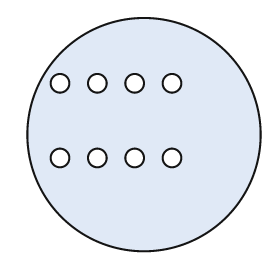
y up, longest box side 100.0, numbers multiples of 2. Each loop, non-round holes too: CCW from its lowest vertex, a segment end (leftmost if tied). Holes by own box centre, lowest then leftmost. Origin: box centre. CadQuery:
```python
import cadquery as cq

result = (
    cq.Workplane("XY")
    .moveTo(0.0, 0.0)
    .circle(50.0)
    .moveTo(-36.0, -10.0)
    .circle(4.0)
    .moveTo(-20.0, -10.0)
    .circle(4.0)
    .moveTo(-4.0, -10.0)
    .circle(4.0)
    .moveTo(12.0, -10.0)
    .circle(4.0)
    .moveTo(-36.0, 22.0)
    .circle(4.0)
    .moveTo(-20.0, 22.0)
    .circle(4.0)
    .moveTo(-4.0, 22.0)
    .circle(4.0)
    .moveTo(12.0, 22.0)
    .circle(4.0)
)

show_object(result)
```